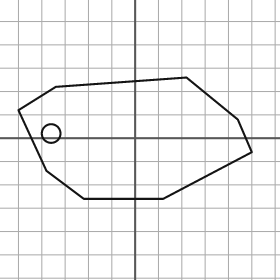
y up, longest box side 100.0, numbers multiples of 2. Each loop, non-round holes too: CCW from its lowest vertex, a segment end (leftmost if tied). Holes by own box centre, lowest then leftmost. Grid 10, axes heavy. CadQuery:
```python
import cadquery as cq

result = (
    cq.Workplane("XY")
    .moveTo(-22.0, -26.0)
    .lineTo(12.0, -26.0)
    .lineTo(50.0, -6.0)
    .lineTo(44.0, 8.0)
    .lineTo(22.0, 26.0)
    .lineTo(-34.0, 22.0)
    .lineTo(-50.0, 12.0)
    .lineTo(-38.0, -14.0)
    .close()
    .moveTo(-36.0, 2.0)
    .circle(4.0)
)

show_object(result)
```